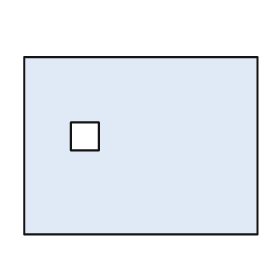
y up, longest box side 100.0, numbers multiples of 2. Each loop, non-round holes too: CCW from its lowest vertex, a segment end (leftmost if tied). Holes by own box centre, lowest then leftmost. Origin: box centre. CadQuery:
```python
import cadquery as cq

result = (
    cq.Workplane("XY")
    .moveTo(-50.0, -38.0)
    .lineTo(50.0, -38.0)
    .lineTo(50.0, 38.0)
    .lineTo(-50.0, 38.0)
    .close()
    .moveTo(-30.0, -2.0)
    .lineTo(-18.0, -2.0)
    .lineTo(-18.0, 10.0)
    .lineTo(-30.0, 10.0)
    .close()
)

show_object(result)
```